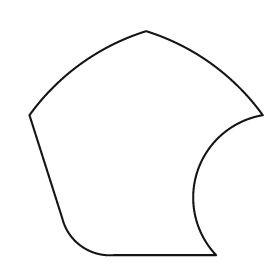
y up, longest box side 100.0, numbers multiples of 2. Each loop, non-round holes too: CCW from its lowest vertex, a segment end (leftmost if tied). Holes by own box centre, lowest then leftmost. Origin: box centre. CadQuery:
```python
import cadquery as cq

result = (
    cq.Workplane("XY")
    .moveTo(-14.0, -48.0)
    .lineTo(30.0, -48.0)
    .threePointArc((22.0, -12.0), (50.0, 12.0))
    .threePointArc((28.0, 34.0), (0.0, 48.0))
    .threePointArc((-28.0, 34.0), (-50.0, 12.0))
    .lineTo(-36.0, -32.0)
    .threePointArc((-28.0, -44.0), (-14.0, -48.0))
    .close()
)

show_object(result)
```